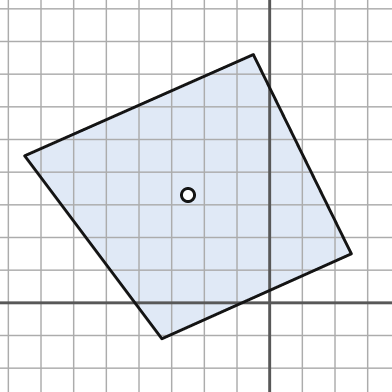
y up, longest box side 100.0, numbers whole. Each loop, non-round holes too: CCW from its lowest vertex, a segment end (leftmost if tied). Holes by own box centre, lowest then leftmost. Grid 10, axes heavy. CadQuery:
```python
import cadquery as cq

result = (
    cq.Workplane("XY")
    .moveTo(-33.0, -11.0)
    .lineTo(25.0, 15.0)
    .lineTo(-5.0, 76.0)
    .lineTo(-75.0, 45.0)
    .close()
    .moveTo(-25.0, 33.0)
    .circle(2.0)
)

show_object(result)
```